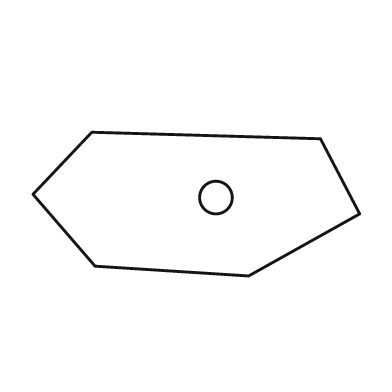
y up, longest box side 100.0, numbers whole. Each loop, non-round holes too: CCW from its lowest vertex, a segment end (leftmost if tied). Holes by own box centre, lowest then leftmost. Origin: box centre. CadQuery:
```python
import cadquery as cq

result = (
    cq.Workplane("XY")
    .moveTo(16.0, -22.0)
    .lineTo(50.0, -3.0)
    .lineTo(38.0, 20.0)
    .lineTo(-32.0, 22.0)
    .lineTo(-50.0, 3.0)
    .lineTo(-31.0, -19.0)
    .close()
    .moveTo(6.0, 2.0)
    .circle(5.0)
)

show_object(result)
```